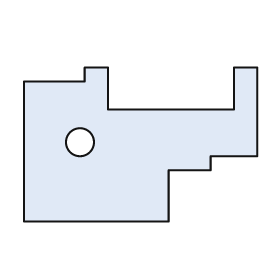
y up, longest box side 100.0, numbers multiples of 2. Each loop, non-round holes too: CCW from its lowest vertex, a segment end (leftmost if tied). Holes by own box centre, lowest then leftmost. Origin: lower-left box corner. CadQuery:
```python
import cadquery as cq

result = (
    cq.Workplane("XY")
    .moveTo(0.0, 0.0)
    .lineTo(62.0, 0.0)
    .lineTo(62.0, 22.0)
    .lineTo(80.0, 22.0)
    .lineTo(80.0, 28.0)
    .lineTo(100.0, 28.0)
    .lineTo(100.0, 66.0)
    .lineTo(90.0, 66.0)
    .lineTo(90.0, 48.0)
    .lineTo(36.0, 48.0)
    .lineTo(36.0, 66.0)
    .lineTo(26.0, 66.0)
    .lineTo(26.0, 60.0)
    .lineTo(0.0, 60.0)
    .close()
    .moveTo(24.0, 34.0)
    .circle(6.0)
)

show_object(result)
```